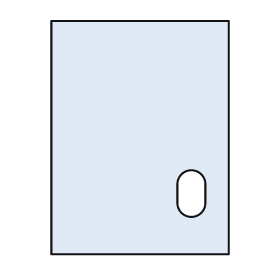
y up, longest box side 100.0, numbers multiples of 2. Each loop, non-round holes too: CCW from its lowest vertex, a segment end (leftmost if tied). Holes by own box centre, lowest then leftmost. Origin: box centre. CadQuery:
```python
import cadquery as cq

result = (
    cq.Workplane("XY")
    .moveTo(-38.0, -50.0)
    .lineTo(38.0, -50.0)
    .lineTo(38.0, 50.0)
    .lineTo(-38.0, 50.0)
    .close()
    .moveTo(16.0, -28.0)
    .threePointArc((22.0, -34.0), (28.0, -28.0))
    .lineTo(28.0, -20.0)
    .threePointArc((22.0, -14.0), (16.0, -20.0))
    .close()
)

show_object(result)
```